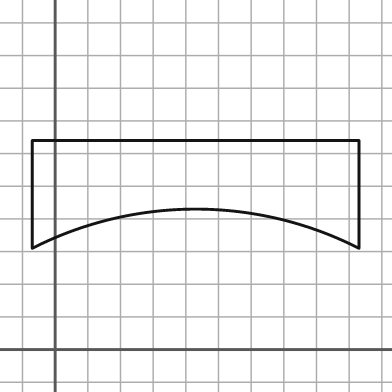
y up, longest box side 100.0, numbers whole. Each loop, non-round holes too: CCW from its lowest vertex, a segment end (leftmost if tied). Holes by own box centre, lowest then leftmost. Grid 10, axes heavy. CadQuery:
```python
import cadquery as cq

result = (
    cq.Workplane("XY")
    .moveTo(-7.0, 31.0)
    .threePointArc((43.0, 43.0), (93.0, 31.0))
    .lineTo(93.0, 64.0)
    .lineTo(-7.0, 64.0)
    .close()
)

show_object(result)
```